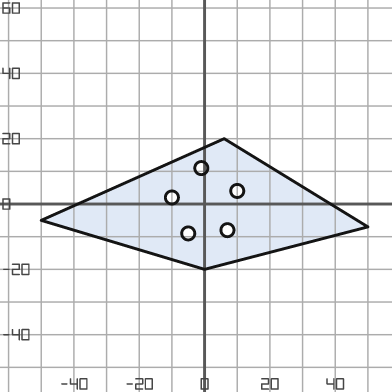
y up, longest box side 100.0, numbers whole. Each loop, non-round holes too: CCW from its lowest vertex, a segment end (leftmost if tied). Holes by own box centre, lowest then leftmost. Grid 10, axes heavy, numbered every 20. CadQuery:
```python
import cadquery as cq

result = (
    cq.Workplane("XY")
    .moveTo(0.0, -20.0)
    .lineTo(50.0, -7.0)
    .lineTo(6.0, 20.0)
    .lineTo(-50.0, -5.0)
    .close()
    .moveTo(-5.0, -9.0)
    .circle(2.0)
    .moveTo(7.0, -8.0)
    .circle(2.0)
    .moveTo(-10.0, 2.0)
    .circle(2.0)
    .moveTo(10.0, 4.0)
    .circle(2.0)
    .moveTo(-1.0, 11.0)
    .circle(2.0)
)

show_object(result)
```